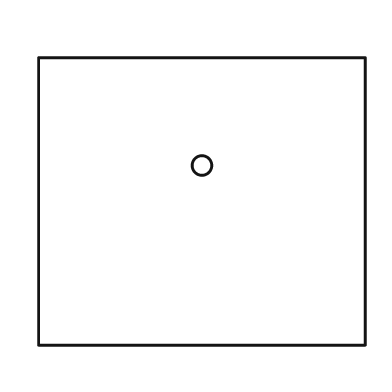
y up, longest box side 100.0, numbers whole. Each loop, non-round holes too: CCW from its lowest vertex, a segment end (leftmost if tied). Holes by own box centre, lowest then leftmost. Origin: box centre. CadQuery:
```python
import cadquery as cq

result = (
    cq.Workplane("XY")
    .moveTo(-50.0, -44.0)
    .lineTo(50.0, -44.0)
    .lineTo(50.0, 44.0)
    .lineTo(-50.0, 44.0)
    .close()
    .moveTo(0.0, 11.0)
    .circle(3.0)
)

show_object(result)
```